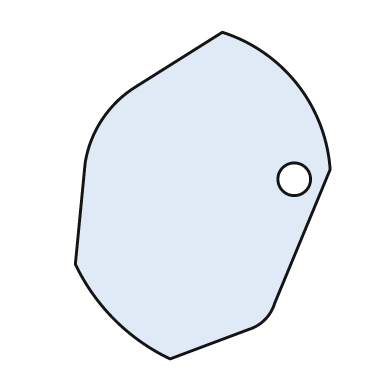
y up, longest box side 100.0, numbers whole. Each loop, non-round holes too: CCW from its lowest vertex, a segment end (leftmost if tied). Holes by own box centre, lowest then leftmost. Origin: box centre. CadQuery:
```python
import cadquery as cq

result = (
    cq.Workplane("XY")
    .moveTo(-10.0, -50.0)
    .lineTo(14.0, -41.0)
    .threePointArc((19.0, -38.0), (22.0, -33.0))
    .lineTo(39.0, 8.0)
    .threePointArc((29.0, 34.0), (6.0, 50.0))
    .lineTo(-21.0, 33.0)
    .threePointArc((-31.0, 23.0), (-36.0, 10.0))
    .lineTo(-39.0, -21.0)
    .threePointArc((-27.0, -38.0), (-10.0, -50.0))
    .close()
    .moveTo(28.0, 5.0)
    .circle(5.0)
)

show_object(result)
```